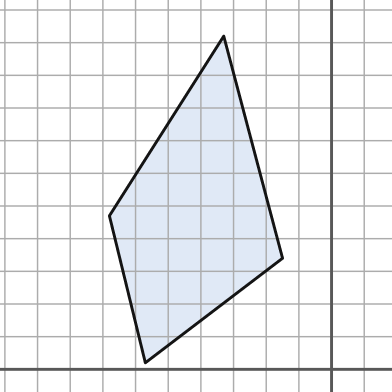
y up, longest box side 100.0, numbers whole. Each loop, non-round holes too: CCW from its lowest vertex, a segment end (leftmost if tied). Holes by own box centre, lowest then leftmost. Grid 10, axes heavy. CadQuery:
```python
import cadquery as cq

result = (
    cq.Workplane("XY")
    .moveTo(-57.0, 2.0)
    .lineTo(-15.0, 34.0)
    .lineTo(-33.0, 102.0)
    .lineTo(-68.0, 47.0)
    .close()
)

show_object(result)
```